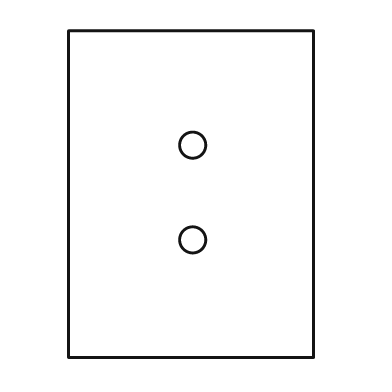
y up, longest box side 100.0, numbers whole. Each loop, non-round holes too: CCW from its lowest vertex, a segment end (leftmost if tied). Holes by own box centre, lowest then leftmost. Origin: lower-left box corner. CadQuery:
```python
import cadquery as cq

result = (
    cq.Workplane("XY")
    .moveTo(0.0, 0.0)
    .lineTo(75.0, 0.0)
    .lineTo(75.0, 100.0)
    .lineTo(0.0, 100.0)
    .close()
    .moveTo(38.0, 36.0)
    .circle(4.0)
    .moveTo(38.0, 65.0)
    .circle(4.0)
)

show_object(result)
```